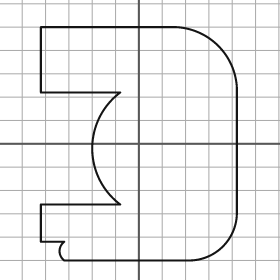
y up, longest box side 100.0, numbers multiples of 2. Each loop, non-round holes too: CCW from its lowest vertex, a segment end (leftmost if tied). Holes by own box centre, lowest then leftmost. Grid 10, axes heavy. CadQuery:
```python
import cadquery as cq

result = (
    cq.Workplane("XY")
    .moveTo(-32.0, -50.0)
    .lineTo(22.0, -50.0)
    .threePointArc((36.0, -44.0), (42.0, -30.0))
    .lineTo(42.0, 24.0)
    .threePointArc((34.0, 42.0), (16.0, 50.0))
    .lineTo(-42.0, 50.0)
    .lineTo(-42.0, 22.0)
    .lineTo(-8.0, 22.0)
    .threePointArc((-20.0, -2.0), (-8.0, -26.0))
    .lineTo(-42.0, -26.0)
    .lineTo(-42.0, -42.0)
    .lineTo(-32.0, -42.0)
    .threePointArc((-34.0, -46.0), (-32.0, -50.0))
    .close()
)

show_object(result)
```